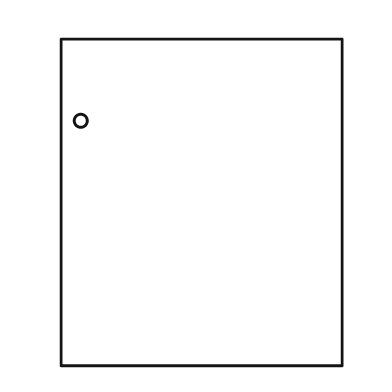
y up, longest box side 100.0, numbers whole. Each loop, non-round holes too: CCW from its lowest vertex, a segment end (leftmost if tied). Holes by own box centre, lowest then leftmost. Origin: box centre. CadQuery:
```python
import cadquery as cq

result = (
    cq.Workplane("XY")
    .moveTo(-43.0, -50.0)
    .lineTo(43.0, -50.0)
    .lineTo(43.0, 50.0)
    .lineTo(-43.0, 50.0)
    .close()
    .moveTo(-37.0, 25.0)
    .circle(2.0)
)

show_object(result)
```